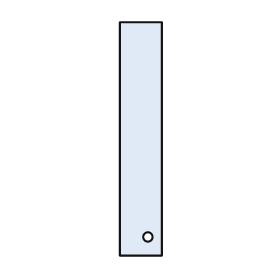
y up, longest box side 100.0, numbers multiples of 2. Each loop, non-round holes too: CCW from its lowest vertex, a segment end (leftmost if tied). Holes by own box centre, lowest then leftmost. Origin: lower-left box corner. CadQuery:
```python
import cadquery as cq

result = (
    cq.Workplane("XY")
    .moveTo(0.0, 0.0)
    .lineTo(18.0, 0.0)
    .lineTo(18.0, 100.0)
    .lineTo(0.0, 100.0)
    .close()
    .moveTo(12.0, 8.0)
    .circle(2.0)
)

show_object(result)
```